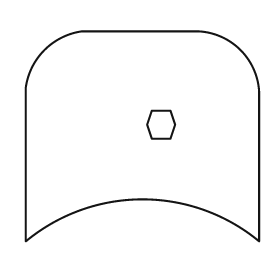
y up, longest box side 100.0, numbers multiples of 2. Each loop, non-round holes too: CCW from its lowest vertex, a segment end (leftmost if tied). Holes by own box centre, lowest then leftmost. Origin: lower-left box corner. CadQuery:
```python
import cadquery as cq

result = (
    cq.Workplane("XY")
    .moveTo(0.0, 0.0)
    .threePointArc((50.0, 18.0), (100.0, 0.0))
    .lineTo(100.0, 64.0)
    .threePointArc((92.0, 82.0), (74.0, 90.0))
    .lineTo(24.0, 90.0)
    .threePointArc((8.0, 82.0), (0.0, 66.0))
    .close()
    .moveTo(54.0, 44.0)
    .lineTo(62.0, 44.0)
    .lineTo(64.0, 50.0)
    .lineTo(62.0, 56.0)
    .lineTo(54.0, 56.0)
    .lineTo(52.0, 50.0)
    .close()
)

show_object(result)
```